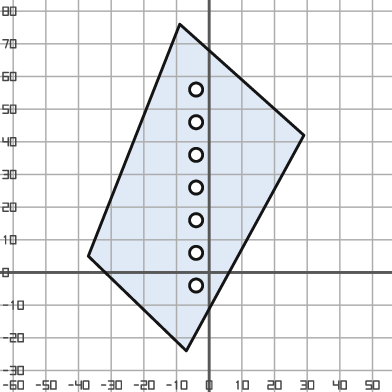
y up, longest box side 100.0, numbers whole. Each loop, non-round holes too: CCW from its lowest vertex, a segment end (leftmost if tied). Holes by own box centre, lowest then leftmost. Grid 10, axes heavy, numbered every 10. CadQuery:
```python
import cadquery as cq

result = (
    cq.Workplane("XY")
    .moveTo(-7.0, -24.0)
    .lineTo(29.0, 42.0)
    .lineTo(-9.0, 76.0)
    .lineTo(-37.0, 5.0)
    .close()
    .moveTo(-4.0, -4.0)
    .circle(2.0)
    .moveTo(-4.0, 6.0)
    .circle(2.0)
    .moveTo(-4.0, 16.0)
    .circle(2.0)
    .moveTo(-4.0, 26.0)
    .circle(2.0)
    .moveTo(-4.0, 36.0)
    .circle(2.0)
    .moveTo(-4.0, 46.0)
    .circle(2.0)
    .moveTo(-4.0, 56.0)
    .circle(2.0)
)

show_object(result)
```